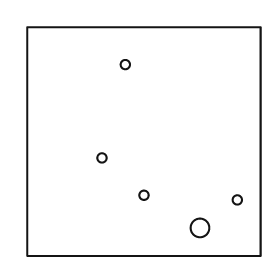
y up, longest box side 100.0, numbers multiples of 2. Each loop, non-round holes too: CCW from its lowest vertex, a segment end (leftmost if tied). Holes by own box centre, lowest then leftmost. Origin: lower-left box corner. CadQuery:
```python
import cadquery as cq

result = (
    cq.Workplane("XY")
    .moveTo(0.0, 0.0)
    .lineTo(100.0, 0.0)
    .lineTo(100.0, 98.0)
    .lineTo(0.0, 98.0)
    .close()
    .moveTo(74.0, 12.0)
    .circle(4.0)
    .moveTo(90.0, 24.0)
    .circle(2.0)
    .moveTo(50.0, 26.0)
    .circle(2.0)
    .moveTo(32.0, 42.0)
    .circle(2.0)
    .moveTo(42.0, 82.0)
    .circle(2.0)
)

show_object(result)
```